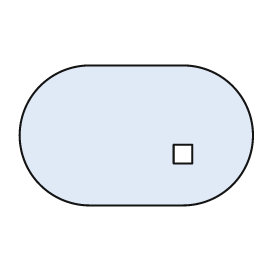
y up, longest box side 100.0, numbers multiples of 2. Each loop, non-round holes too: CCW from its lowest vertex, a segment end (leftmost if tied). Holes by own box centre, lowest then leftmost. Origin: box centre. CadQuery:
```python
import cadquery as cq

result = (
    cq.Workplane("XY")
    .moveTo(-20.0, -30.0)
    .lineTo(20.0, -30.0)
    .threePointArc((50.0, 0.0), (20.0, 30.0))
    .lineTo(-20.0, 30.0)
    .threePointArc((-50.0, 0.0), (-20.0, -30.0))
    .close()
    .moveTo(16.0, -12.0)
    .lineTo(24.0, -12.0)
    .lineTo(24.0, -4.0)
    .lineTo(16.0, -4.0)
    .close()
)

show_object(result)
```